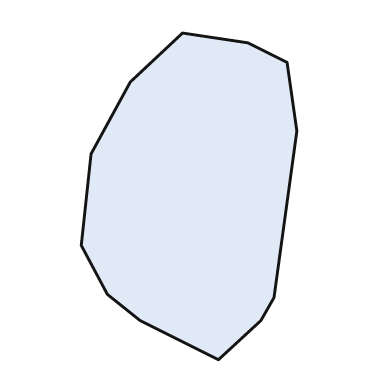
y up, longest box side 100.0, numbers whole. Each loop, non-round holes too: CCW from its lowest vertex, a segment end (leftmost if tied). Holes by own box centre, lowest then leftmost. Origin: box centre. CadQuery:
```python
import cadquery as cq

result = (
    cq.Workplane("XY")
    .moveTo(9.0, -50.0)
    .lineTo(22.0, -38.0)
    .lineTo(26.0, -31.0)
    .lineTo(33.0, 20.0)
    .lineTo(30.0, 41.0)
    .lineTo(18.0, 47.0)
    .lineTo(-2.0, 50.0)
    .lineTo(-18.0, 35.0)
    .lineTo(-30.0, 13.0)
    .lineTo(-33.0, -15.0)
    .lineTo(-25.0, -30.0)
    .lineTo(-15.0, -38.0)
    .close()
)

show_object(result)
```